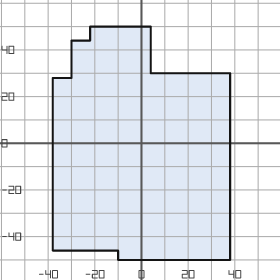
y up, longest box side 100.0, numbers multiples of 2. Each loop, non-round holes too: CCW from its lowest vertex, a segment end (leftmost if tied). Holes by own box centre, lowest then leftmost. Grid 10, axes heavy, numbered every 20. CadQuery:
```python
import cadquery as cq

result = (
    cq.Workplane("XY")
    .moveTo(-10.0, -50.0)
    .lineTo(38.0, -50.0)
    .lineTo(38.0, 30.0)
    .lineTo(4.0, 30.0)
    .lineTo(4.0, 50.0)
    .lineTo(-22.0, 50.0)
    .lineTo(-22.0, 44.0)
    .lineTo(-30.0, 44.0)
    .lineTo(-30.0, 28.0)
    .lineTo(-38.0, 28.0)
    .lineTo(-38.0, -46.0)
    .lineTo(-10.0, -46.0)
    .close()
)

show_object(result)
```